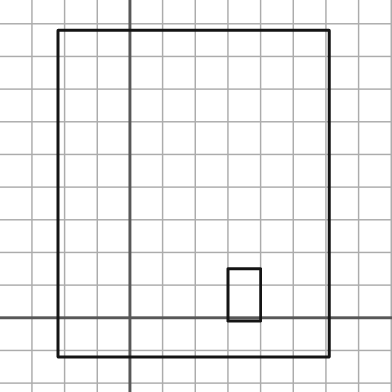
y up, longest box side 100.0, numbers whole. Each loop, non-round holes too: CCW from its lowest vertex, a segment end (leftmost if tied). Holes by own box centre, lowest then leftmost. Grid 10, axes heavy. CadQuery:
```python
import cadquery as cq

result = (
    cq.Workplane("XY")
    .moveTo(-22.0, -12.0)
    .lineTo(61.0, -12.0)
    .lineTo(61.0, 88.0)
    .lineTo(-22.0, 88.0)
    .close()
    .moveTo(30.0, -1.0)
    .lineTo(40.0, -1.0)
    .lineTo(40.0, 15.0)
    .lineTo(30.0, 15.0)
    .close()
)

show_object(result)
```